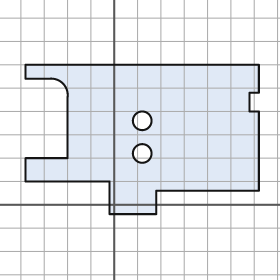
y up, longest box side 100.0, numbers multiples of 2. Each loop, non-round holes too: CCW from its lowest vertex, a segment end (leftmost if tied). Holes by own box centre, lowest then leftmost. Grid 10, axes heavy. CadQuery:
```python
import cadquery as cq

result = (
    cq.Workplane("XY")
    .moveTo(-2.0, -4.0)
    .lineTo(18.0, -4.0)
    .lineTo(18.0, 6.0)
    .lineTo(62.0, 6.0)
    .lineTo(62.0, 40.0)
    .lineTo(58.0, 40.0)
    .lineTo(58.0, 48.0)
    .lineTo(62.0, 48.0)
    .lineTo(62.0, 60.0)
    .lineTo(-38.0, 60.0)
    .lineTo(-38.0, 54.0)
    .lineTo(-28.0, 54.0)
    .threePointArc((-22.0, 52.0), (-20.0, 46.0))
    .lineTo(-20.0, 20.0)
    .lineTo(-38.0, 20.0)
    .lineTo(-38.0, 10.0)
    .lineTo(-2.0, 10.0)
    .close()
    .moveTo(12.0, 22.0)
    .circle(4.0)
    .moveTo(12.0, 36.0)
    .circle(4.0)
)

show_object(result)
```